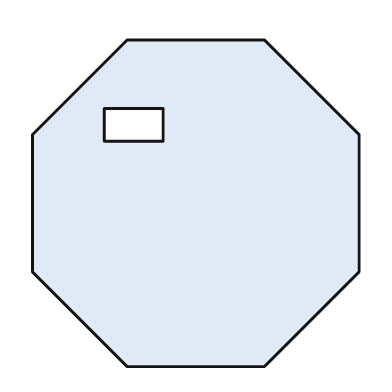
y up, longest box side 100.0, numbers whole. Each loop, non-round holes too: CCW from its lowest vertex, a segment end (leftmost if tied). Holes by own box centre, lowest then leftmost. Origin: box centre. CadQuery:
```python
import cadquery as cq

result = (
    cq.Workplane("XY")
    .moveTo(-21.0, -50.0)
    .lineTo(21.0, -50.0)
    .lineTo(50.0, -21.0)
    .lineTo(50.0, 21.0)
    .lineTo(21.0, 50.0)
    .lineTo(-21.0, 50.0)
    .lineTo(-50.0, 21.0)
    .lineTo(-50.0, -21.0)
    .close()
    .moveTo(-28.0, 19.0)
    .lineTo(-10.0, 19.0)
    .lineTo(-10.0, 29.0)
    .lineTo(-28.0, 29.0)
    .close()
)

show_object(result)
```